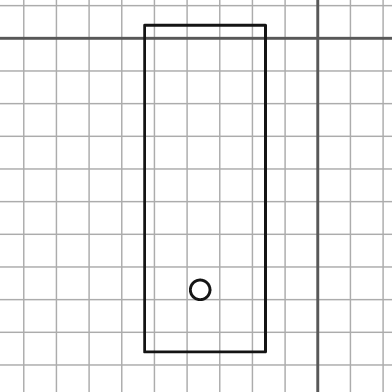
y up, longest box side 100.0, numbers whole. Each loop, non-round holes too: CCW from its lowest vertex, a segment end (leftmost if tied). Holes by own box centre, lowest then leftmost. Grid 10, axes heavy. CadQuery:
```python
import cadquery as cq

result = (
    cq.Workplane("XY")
    .moveTo(-53.0, -96.0)
    .lineTo(-16.0, -96.0)
    .lineTo(-16.0, 4.0)
    .lineTo(-53.0, 4.0)
    .close()
    .moveTo(-36.0, -77.0)
    .circle(3.0)
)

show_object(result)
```